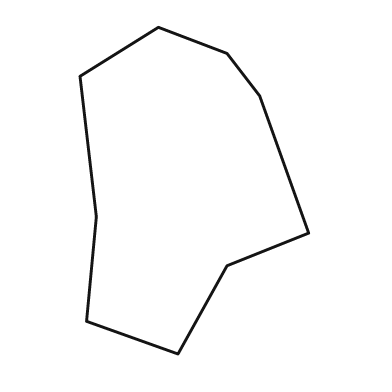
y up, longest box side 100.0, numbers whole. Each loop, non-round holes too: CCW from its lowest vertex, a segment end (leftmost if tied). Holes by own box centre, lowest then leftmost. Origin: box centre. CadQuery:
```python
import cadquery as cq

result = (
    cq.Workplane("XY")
    .moveTo(-5.0, -50.0)
    .lineTo(10.0, -23.0)
    .lineTo(35.0, -13.0)
    .lineTo(20.0, 29.0)
    .lineTo(10.0, 42.0)
    .lineTo(-11.0, 50.0)
    .lineTo(-35.0, 35.0)
    .lineTo(-30.0, -8.0)
    .lineTo(-33.0, -40.0)
    .close()
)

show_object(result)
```